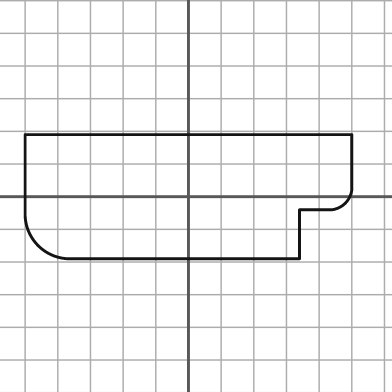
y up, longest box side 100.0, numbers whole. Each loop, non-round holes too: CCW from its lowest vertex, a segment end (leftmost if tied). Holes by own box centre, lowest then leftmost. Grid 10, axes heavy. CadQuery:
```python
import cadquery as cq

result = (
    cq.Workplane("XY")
    .moveTo(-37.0, -19.0)
    .lineTo(34.0, -19.0)
    .lineTo(34.0, -4.0)
    .lineTo(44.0, -4.0)
    .threePointArc((48.0, -2.0), (50.0, 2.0))
    .lineTo(50.0, 19.0)
    .lineTo(-50.0, 19.0)
    .lineTo(-50.0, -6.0)
    .threePointArc((-46.0, -15.0), (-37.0, -19.0))
    .close()
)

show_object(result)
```